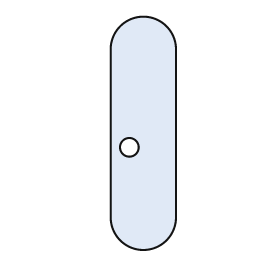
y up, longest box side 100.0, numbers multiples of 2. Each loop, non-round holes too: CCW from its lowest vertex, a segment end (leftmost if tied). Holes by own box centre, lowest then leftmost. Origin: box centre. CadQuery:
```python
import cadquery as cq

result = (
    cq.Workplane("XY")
    .moveTo(-14.0, -36.0)
    .threePointArc((0.0, -50.0), (14.0, -36.0))
    .lineTo(14.0, 36.0)
    .threePointArc((0.0, 50.0), (-14.0, 36.0))
    .close()
    .moveTo(-6.0, -6.0)
    .circle(4.0)
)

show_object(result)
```